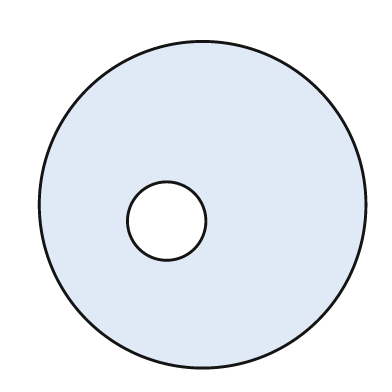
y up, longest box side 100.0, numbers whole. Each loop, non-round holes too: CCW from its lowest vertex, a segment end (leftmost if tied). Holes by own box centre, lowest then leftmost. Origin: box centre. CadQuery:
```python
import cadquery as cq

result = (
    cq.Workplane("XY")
    .moveTo(0.0, 0.0)
    .circle(50.0)
    .moveTo(-11.0, -5.0)
    .circle(12.0)
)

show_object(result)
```